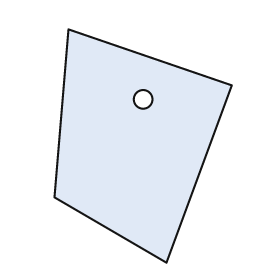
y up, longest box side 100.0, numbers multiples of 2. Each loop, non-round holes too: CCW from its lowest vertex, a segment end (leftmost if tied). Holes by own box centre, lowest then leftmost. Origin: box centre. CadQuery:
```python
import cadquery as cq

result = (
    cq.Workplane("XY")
    .moveTo(10.0, -50.0)
    .lineTo(38.0, 26.0)
    .lineTo(-32.0, 50.0)
    .lineTo(-38.0, -22.0)
    .close()
    .moveTo(0.0, 20.0)
    .circle(4.0)
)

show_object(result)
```